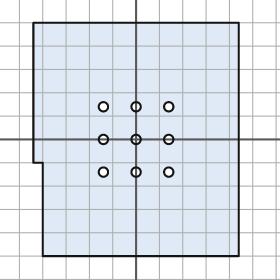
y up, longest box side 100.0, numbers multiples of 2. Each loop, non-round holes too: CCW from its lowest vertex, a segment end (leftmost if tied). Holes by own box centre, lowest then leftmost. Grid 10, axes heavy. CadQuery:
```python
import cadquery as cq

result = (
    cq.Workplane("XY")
    .moveTo(-40.0, -50.0)
    .lineTo(44.0, -50.0)
    .lineTo(44.0, 50.0)
    .lineTo(-44.0, 50.0)
    .lineTo(-44.0, -10.0)
    .lineTo(-40.0, -10.0)
    .close()
    .moveTo(-14.0, -14.0)
    .circle(2.0)
    .moveTo(0.0, -14.0)
    .circle(2.0)
    .moveTo(14.0, -14.0)
    .circle(2.0)
    .moveTo(-14.0, 0.0)
    .circle(2.0)
    .moveTo(0.0, 0.0)
    .circle(2.0)
    .moveTo(14.0, 0.0)
    .circle(2.0)
    .moveTo(-14.0, 14.0)
    .circle(2.0)
    .moveTo(0.0, 14.0)
    .circle(2.0)
    .moveTo(14.0, 14.0)
    .circle(2.0)
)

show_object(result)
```